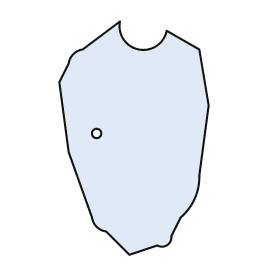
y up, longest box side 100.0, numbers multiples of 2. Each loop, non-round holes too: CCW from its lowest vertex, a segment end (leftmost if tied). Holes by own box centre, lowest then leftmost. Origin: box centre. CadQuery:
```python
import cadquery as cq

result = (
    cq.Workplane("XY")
    .moveTo(-2.0, -50.0)
    .lineTo(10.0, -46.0)
    .threePointArc((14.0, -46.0), (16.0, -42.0))
    .lineTo(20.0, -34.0)
    .threePointArc((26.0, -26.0), (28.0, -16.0))
    .lineTo(32.0, 14.0)
    .lineTo(28.0, 38.0)
    .lineTo(14.0, 46.0)
    .threePointArc((2.0, 38.0), (-6.0, 50.0))
    .lineTo(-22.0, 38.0)
    .threePointArc((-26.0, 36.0), (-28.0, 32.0))
    .lineTo(-32.0, 24.0)
    .lineTo(-28.0, -6.0)
    .lineTo(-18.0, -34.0)
    .threePointArc((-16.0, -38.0), (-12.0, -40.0))
    .close()
    .moveTo(-16.0, 2.0)
    .circle(2.0)
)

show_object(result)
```